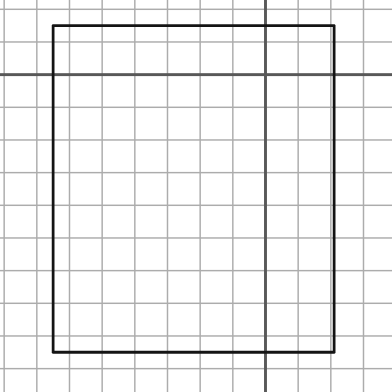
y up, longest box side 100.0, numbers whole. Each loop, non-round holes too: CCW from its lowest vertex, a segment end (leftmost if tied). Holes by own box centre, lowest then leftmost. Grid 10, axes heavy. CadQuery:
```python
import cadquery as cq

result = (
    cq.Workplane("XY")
    .moveTo(-65.0, -85.0)
    .lineTo(21.0, -85.0)
    .lineTo(21.0, 15.0)
    .lineTo(-65.0, 15.0)
    .close()
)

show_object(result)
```